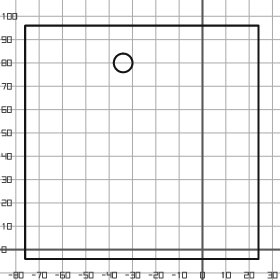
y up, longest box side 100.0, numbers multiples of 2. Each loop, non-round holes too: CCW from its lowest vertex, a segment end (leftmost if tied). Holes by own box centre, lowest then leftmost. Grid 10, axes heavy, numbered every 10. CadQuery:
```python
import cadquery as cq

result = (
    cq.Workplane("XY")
    .moveTo(-76.0, -4.0)
    .lineTo(24.0, -4.0)
    .lineTo(24.0, 96.0)
    .lineTo(-76.0, 96.0)
    .close()
    .moveTo(-34.0, 80.0)
    .circle(4.0)
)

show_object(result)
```